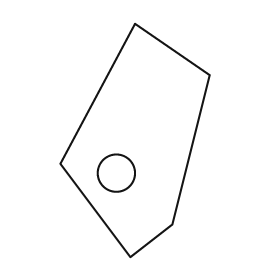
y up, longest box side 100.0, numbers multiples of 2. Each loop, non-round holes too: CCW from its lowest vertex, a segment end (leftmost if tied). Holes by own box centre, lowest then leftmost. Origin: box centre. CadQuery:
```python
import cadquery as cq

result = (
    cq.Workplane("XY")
    .moveTo(-2.0, -50.0)
    .lineTo(16.0, -36.0)
    .lineTo(32.0, 28.0)
    .lineTo(0.0, 50.0)
    .lineTo(-32.0, -10.0)
    .close()
    .moveTo(-8.0, -14.0)
    .circle(8.0)
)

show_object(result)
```